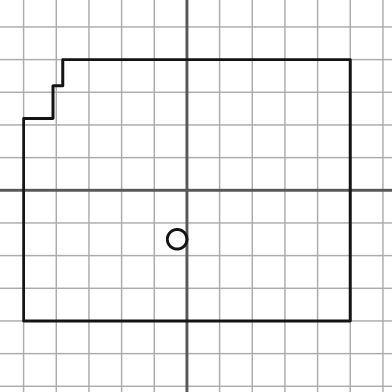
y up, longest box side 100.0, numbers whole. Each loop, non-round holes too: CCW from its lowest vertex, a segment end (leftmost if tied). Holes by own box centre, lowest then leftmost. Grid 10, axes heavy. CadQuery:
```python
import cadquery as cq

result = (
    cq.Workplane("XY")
    .moveTo(-50.0, -40.0)
    .lineTo(50.0, -40.0)
    .lineTo(50.0, 40.0)
    .lineTo(-38.0, 40.0)
    .lineTo(-38.0, 32.0)
    .lineTo(-41.0, 32.0)
    .lineTo(-41.0, 22.0)
    .lineTo(-50.0, 22.0)
    .close()
    .moveTo(-3.0, -15.0)
    .circle(3.0)
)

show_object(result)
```